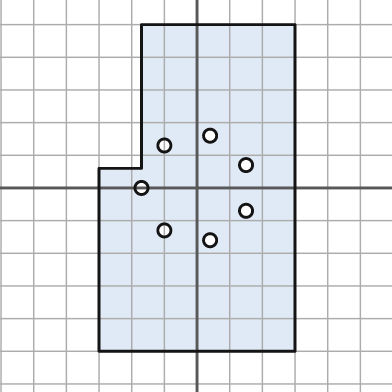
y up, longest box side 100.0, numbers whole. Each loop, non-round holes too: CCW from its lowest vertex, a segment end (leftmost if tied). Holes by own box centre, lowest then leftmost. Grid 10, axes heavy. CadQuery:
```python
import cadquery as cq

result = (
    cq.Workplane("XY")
    .moveTo(-30.0, -50.0)
    .lineTo(30.0, -50.0)
    .lineTo(30.0, 50.0)
    .lineTo(-17.0, 50.0)
    .lineTo(-17.0, 6.0)
    .lineTo(-30.0, 6.0)
    .close()
    .moveTo(4.0, -16.0)
    .circle(2.0)
    .moveTo(-10.0, -13.0)
    .circle(2.0)
    .moveTo(15.0, -7.0)
    .circle(2.0)
    .moveTo(-17.0, 0.0)
    .circle(2.0)
    .moveTo(15.0, 7.0)
    .circle(2.0)
    .moveTo(-10.0, 13.0)
    .circle(2.0)
    .moveTo(4.0, 16.0)
    .circle(2.0)
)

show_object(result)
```